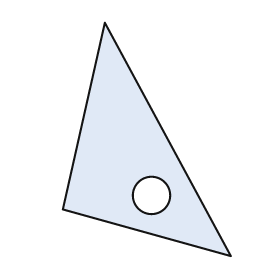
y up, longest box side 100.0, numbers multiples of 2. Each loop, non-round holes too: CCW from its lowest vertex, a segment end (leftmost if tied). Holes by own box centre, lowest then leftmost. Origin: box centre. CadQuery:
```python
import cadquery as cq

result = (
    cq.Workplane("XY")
    .moveTo(36.0, -50.0)
    .lineTo(-18.0, 50.0)
    .lineTo(-36.0, -30.0)
    .close()
    .moveTo(2.0, -24.0)
    .circle(8.0)
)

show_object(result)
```